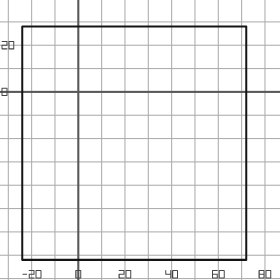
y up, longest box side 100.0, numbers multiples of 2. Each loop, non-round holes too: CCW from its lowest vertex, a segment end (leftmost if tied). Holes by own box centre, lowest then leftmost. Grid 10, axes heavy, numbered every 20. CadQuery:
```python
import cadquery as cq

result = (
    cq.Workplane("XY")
    .moveTo(-24.0, -72.0)
    .lineTo(72.0, -72.0)
    .lineTo(72.0, 28.0)
    .lineTo(-24.0, 28.0)
    .close()
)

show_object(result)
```